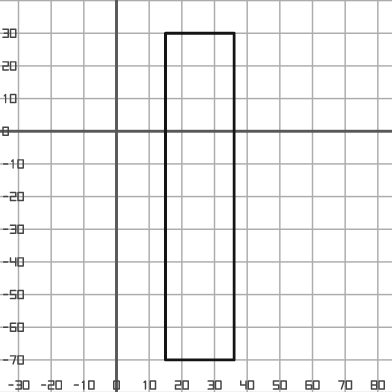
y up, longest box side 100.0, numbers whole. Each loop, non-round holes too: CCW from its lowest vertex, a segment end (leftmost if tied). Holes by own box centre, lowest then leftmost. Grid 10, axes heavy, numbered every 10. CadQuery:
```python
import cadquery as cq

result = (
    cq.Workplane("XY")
    .moveTo(15.0, -70.0)
    .lineTo(36.0, -70.0)
    .lineTo(36.0, 30.0)
    .lineTo(15.0, 30.0)
    .close()
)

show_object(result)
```